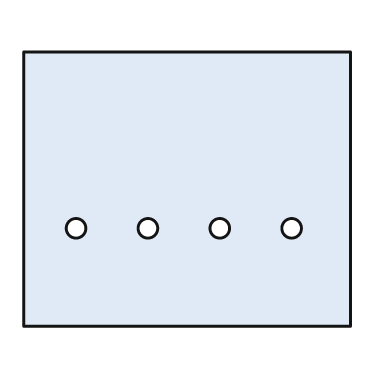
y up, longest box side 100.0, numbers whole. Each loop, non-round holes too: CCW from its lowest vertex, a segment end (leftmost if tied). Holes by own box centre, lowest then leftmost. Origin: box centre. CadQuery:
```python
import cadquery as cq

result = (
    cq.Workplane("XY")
    .moveTo(-50.0, -42.0)
    .lineTo(50.0, -42.0)
    .lineTo(50.0, 42.0)
    .lineTo(-50.0, 42.0)
    .close()
    .moveTo(-34.0, -12.0)
    .circle(3.0)
    .moveTo(-12.0, -12.0)
    .circle(3.0)
    .moveTo(10.0, -12.0)
    .circle(3.0)
    .moveTo(32.0, -12.0)
    .circle(3.0)
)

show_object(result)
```